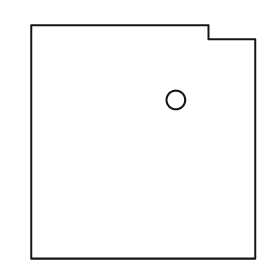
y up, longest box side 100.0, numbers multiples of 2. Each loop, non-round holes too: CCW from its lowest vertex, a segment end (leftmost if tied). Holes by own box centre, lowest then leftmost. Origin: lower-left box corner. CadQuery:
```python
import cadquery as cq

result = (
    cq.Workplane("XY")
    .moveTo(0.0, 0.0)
    .lineTo(96.0, 0.0)
    .lineTo(96.0, 94.0)
    .lineTo(76.0, 94.0)
    .lineTo(76.0, 100.0)
    .lineTo(0.0, 100.0)
    .close()
    .moveTo(62.0, 68.0)
    .circle(4.0)
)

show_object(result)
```